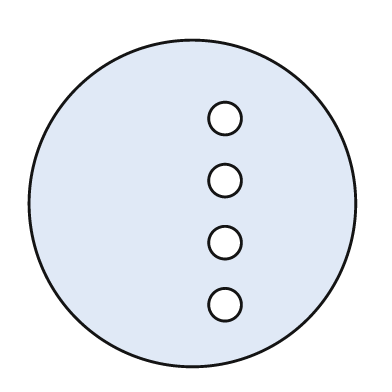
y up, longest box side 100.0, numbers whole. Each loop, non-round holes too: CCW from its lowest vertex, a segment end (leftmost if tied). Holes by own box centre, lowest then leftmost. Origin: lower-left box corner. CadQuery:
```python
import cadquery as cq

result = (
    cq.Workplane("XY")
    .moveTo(50.0, 50.0)
    .circle(50.0)
    .moveTo(60.0, 19.0)
    .circle(5.0)
    .moveTo(60.0, 38.0)
    .circle(5.0)
    .moveTo(60.0, 57.0)
    .circle(5.0)
    .moveTo(60.0, 76.0)
    .circle(5.0)
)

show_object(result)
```